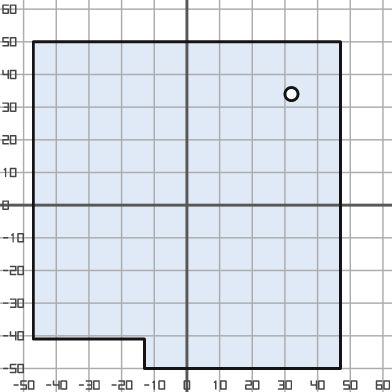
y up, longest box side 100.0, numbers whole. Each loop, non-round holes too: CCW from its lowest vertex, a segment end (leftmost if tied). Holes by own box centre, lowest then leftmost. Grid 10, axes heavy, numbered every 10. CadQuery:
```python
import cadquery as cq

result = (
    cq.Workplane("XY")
    .moveTo(-13.0, -50.0)
    .lineTo(47.0, -50.0)
    .lineTo(47.0, 50.0)
    .lineTo(-47.0, 50.0)
    .lineTo(-47.0, -41.0)
    .lineTo(-13.0, -41.0)
    .close()
    .moveTo(32.0, 34.0)
    .circle(2.0)
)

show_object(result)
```